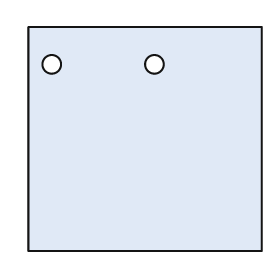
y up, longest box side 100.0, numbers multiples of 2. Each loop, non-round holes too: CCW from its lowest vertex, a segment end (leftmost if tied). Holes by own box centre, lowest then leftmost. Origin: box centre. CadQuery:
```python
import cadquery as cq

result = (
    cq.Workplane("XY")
    .moveTo(-50.0, -48.0)
    .lineTo(50.0, -48.0)
    .lineTo(50.0, 48.0)
    .lineTo(-50.0, 48.0)
    .close()
    .moveTo(-40.0, 32.0)
    .circle(4.0)
    .moveTo(4.0, 32.0)
    .circle(4.0)
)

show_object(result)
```